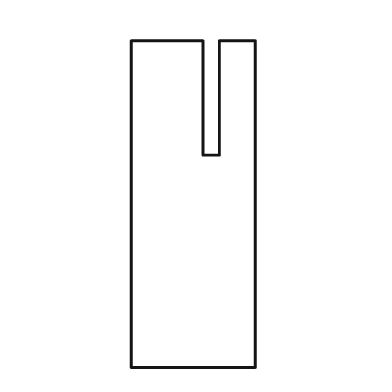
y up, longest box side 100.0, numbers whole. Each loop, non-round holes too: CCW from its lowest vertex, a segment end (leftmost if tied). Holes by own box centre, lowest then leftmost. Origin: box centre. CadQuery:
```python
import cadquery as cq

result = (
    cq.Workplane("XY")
    .moveTo(-19.0, -50.0)
    .lineTo(19.0, -50.0)
    .lineTo(19.0, 50.0)
    .lineTo(8.0, 50.0)
    .lineTo(8.0, 15.0)
    .lineTo(3.0, 15.0)
    .lineTo(3.0, 50.0)
    .lineTo(-19.0, 50.0)
    .close()
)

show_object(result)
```